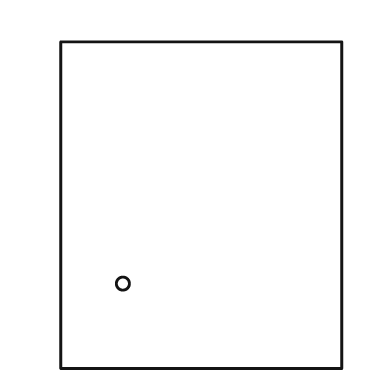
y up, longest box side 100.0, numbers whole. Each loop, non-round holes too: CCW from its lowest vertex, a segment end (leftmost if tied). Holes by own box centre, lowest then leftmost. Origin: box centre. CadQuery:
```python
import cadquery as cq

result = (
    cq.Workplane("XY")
    .moveTo(-43.0, -50.0)
    .lineTo(43.0, -50.0)
    .lineTo(43.0, 50.0)
    .lineTo(-43.0, 50.0)
    .close()
    .moveTo(-24.0, -24.0)
    .circle(2.0)
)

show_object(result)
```